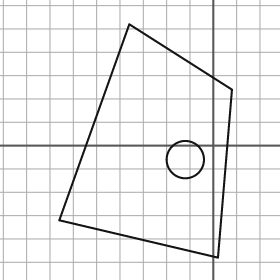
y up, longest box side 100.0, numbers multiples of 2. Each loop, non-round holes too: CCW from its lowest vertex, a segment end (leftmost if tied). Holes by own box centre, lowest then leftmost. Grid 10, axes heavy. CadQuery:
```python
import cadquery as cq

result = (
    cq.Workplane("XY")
    .moveTo(2.0, -48.0)
    .lineTo(8.0, 24.0)
    .lineTo(-36.0, 52.0)
    .lineTo(-66.0, -32.0)
    .close()
    .moveTo(-12.0, -6.0)
    .circle(8.0)
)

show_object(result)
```